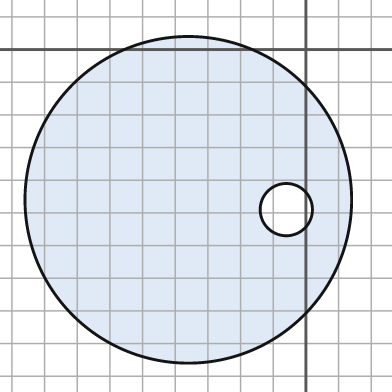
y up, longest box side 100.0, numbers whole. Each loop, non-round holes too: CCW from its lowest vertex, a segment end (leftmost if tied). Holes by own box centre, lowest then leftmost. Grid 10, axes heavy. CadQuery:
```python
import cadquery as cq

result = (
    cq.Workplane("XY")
    .moveTo(-36.0, -46.0)
    .circle(50.0)
    .moveTo(-6.0, -49.0)
    .circle(8.0)
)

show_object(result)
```